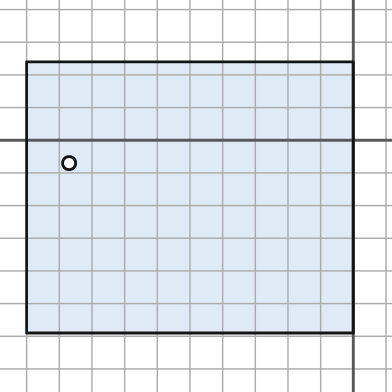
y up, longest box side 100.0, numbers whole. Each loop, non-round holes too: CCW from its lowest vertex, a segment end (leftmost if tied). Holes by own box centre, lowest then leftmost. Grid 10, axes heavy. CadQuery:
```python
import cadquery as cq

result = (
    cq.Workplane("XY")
    .moveTo(-100.0, -59.0)
    .lineTo(0.0, -59.0)
    .lineTo(0.0, 24.0)
    .lineTo(-100.0, 24.0)
    .close()
    .moveTo(-87.0, -7.0)
    .circle(2.0)
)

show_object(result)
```